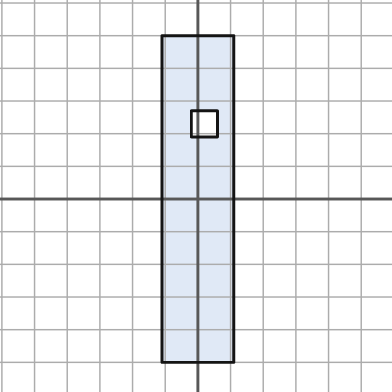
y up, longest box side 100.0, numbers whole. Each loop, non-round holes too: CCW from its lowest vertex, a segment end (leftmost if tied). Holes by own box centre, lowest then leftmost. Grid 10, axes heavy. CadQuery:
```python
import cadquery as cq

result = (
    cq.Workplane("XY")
    .moveTo(-11.0, -50.0)
    .lineTo(11.0, -50.0)
    .lineTo(11.0, 50.0)
    .lineTo(-11.0, 50.0)
    .close()
    .moveTo(-2.0, 19.0)
    .lineTo(6.0, 19.0)
    .lineTo(6.0, 27.0)
    .lineTo(-2.0, 27.0)
    .close()
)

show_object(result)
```